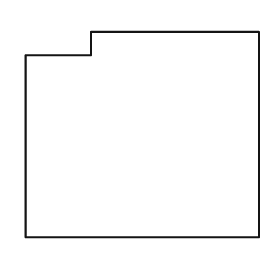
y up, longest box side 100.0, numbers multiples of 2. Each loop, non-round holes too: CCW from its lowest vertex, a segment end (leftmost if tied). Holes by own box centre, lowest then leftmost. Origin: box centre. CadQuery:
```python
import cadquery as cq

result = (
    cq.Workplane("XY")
    .moveTo(-50.0, -44.0)
    .lineTo(50.0, -44.0)
    .lineTo(50.0, 44.0)
    .lineTo(-22.0, 44.0)
    .lineTo(-22.0, 34.0)
    .lineTo(-50.0, 34.0)
    .close()
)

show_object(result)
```